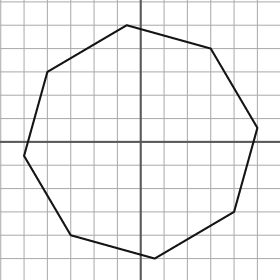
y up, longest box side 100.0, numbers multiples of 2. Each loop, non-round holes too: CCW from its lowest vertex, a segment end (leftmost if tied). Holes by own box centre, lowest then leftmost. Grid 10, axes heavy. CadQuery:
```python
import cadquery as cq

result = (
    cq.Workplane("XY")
    .moveTo(6.0, -50.0)
    .lineTo(40.0, -30.0)
    .lineTo(50.0, 6.0)
    .lineTo(30.0, 40.0)
    .lineTo(-6.0, 50.0)
    .lineTo(-40.0, 30.0)
    .lineTo(-50.0, -6.0)
    .lineTo(-30.0, -40.0)
    .close()
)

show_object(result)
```